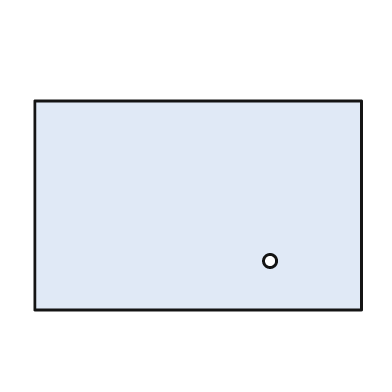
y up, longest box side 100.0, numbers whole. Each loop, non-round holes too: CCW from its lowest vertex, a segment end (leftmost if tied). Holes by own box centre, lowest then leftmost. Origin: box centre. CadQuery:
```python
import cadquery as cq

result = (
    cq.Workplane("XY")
    .moveTo(-50.0, -32.0)
    .lineTo(50.0, -32.0)
    .lineTo(50.0, 32.0)
    .lineTo(-50.0, 32.0)
    .close()
    .moveTo(22.0, -17.0)
    .circle(2.0)
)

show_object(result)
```